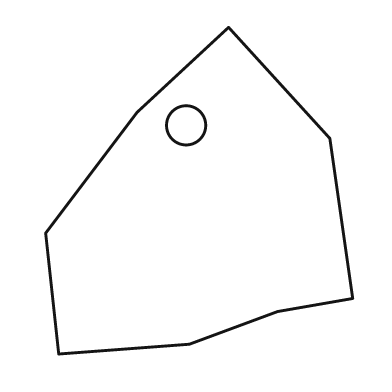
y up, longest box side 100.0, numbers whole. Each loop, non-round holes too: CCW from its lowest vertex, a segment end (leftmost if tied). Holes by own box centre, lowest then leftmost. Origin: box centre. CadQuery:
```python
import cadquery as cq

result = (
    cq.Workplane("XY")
    .moveTo(-43.0, -50.0)
    .lineTo(-3.0, -47.0)
    .lineTo(24.0, -37.0)
    .lineTo(47.0, -33.0)
    .lineTo(40.0, 16.0)
    .lineTo(9.0, 50.0)
    .lineTo(-19.0, 24.0)
    .lineTo(-47.0, -13.0)
    .close()
    .moveTo(-4.0, 20.0)
    .circle(6.0)
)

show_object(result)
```